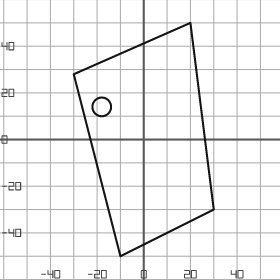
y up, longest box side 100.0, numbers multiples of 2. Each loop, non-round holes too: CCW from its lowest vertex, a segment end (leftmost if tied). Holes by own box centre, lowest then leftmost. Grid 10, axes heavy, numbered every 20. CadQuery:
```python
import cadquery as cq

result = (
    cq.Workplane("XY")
    .moveTo(-10.0, -50.0)
    .lineTo(30.0, -30.0)
    .lineTo(20.0, 50.0)
    .lineTo(-30.0, 28.0)
    .close()
    .moveTo(-18.0, 14.0)
    .circle(4.0)
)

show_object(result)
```